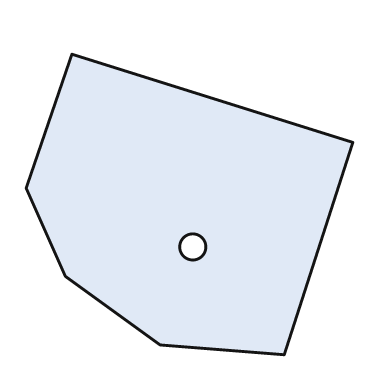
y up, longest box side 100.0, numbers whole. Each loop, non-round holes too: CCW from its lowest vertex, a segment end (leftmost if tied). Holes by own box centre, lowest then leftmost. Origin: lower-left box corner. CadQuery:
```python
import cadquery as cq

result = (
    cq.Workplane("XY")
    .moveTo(79.0, 0.0)
    .lineTo(100.0, 65.0)
    .lineTo(14.0, 92.0)
    .lineTo(0.0, 51.0)
    .lineTo(12.0, 24.0)
    .lineTo(41.0, 3.0)
    .close()
    .moveTo(51.0, 33.0)
    .circle(4.0)
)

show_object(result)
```